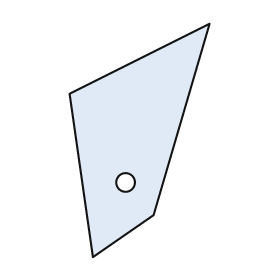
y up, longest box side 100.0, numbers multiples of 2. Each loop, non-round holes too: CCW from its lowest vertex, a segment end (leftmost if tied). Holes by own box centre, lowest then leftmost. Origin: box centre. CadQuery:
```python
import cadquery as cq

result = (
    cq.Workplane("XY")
    .moveTo(-20.0, -50.0)
    .lineTo(6.0, -32.0)
    .lineTo(30.0, 50.0)
    .lineTo(-30.0, 20.0)
    .close()
    .moveTo(-6.0, -18.0)
    .circle(4.0)
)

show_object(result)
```